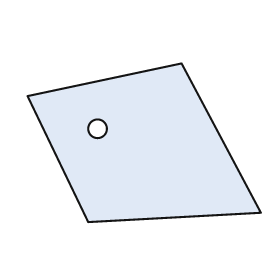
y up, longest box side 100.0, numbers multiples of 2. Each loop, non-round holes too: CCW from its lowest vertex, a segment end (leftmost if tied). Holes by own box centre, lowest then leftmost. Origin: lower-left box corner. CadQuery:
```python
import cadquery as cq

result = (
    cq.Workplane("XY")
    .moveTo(26.0, 0.0)
    .lineTo(100.0, 4.0)
    .lineTo(66.0, 68.0)
    .lineTo(0.0, 54.0)
    .close()
    .moveTo(30.0, 40.0)
    .circle(4.0)
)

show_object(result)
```